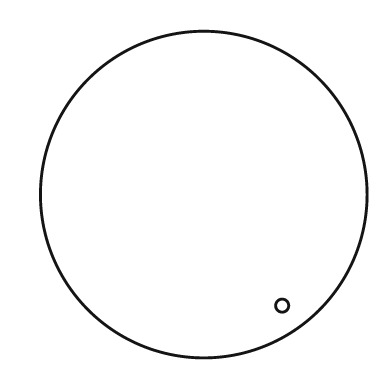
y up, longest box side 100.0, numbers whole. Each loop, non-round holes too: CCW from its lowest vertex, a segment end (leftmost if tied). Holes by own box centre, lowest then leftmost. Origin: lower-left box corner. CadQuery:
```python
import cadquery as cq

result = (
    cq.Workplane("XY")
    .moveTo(50.0, 50.0)
    .circle(50.0)
    .moveTo(74.0, 16.0)
    .circle(2.0)
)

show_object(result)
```